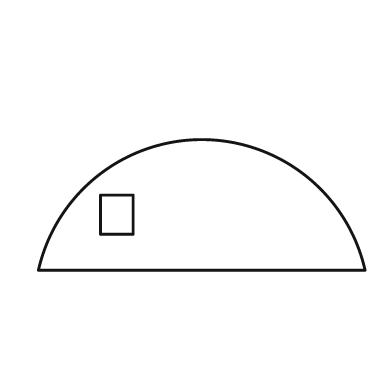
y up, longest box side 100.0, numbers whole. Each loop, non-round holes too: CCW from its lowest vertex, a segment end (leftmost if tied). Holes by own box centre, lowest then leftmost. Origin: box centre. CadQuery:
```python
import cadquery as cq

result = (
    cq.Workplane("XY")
    .moveTo(-50.0, -20.0)
    .lineTo(50.0, -20.0)
    .threePointArc((0.0, 20.0), (-50.0, -20.0))
    .close()
    .moveTo(-31.0, -9.0)
    .lineTo(-21.0, -9.0)
    .lineTo(-21.0, 3.0)
    .lineTo(-31.0, 3.0)
    .close()
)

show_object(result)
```